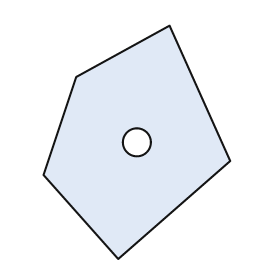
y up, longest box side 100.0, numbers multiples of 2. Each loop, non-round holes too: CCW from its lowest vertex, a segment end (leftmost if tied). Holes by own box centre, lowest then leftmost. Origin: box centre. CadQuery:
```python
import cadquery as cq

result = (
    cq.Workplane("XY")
    .moveTo(-8.0, -50.0)
    .lineTo(40.0, -8.0)
    .lineTo(14.0, 50.0)
    .lineTo(-26.0, 28.0)
    .lineTo(-40.0, -14.0)
    .close()
    .moveTo(0.0, 0.0)
    .circle(6.0)
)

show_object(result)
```